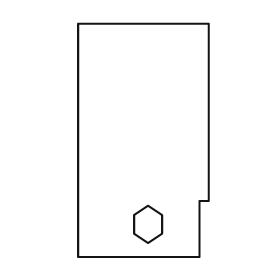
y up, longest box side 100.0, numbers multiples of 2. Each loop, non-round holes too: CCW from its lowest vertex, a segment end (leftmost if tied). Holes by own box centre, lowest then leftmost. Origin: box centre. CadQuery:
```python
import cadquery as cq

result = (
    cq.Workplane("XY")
    .moveTo(-28.0, -50.0)
    .lineTo(24.0, -50.0)
    .lineTo(24.0, -26.0)
    .lineTo(28.0, -26.0)
    .lineTo(28.0, 50.0)
    .lineTo(-28.0, 50.0)
    .close()
    .moveTo(2.0, -44.0)
    .lineTo(8.0, -40.0)
    .lineTo(8.0, -32.0)
    .lineTo(2.0, -28.0)
    .lineTo(-4.0, -32.0)
    .lineTo(-4.0, -40.0)
    .close()
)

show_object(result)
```